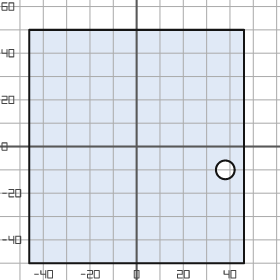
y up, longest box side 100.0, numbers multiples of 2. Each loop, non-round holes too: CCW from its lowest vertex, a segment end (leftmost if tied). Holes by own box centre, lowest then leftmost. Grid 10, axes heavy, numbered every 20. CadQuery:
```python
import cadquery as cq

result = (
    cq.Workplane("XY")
    .moveTo(-46.0, -50.0)
    .lineTo(46.0, -50.0)
    .lineTo(46.0, 50.0)
    .lineTo(-46.0, 50.0)
    .close()
    .moveTo(38.0, -10.0)
    .circle(4.0)
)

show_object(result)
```